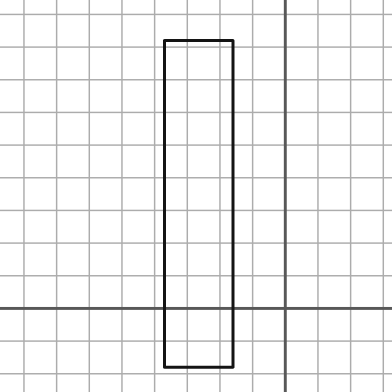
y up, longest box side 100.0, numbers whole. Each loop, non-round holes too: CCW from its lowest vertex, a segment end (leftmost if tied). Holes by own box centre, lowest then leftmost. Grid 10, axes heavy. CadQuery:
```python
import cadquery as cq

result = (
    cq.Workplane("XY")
    .moveTo(-37.0, -18.0)
    .lineTo(-16.0, -18.0)
    .lineTo(-16.0, 82.0)
    .lineTo(-37.0, 82.0)
    .close()
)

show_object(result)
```